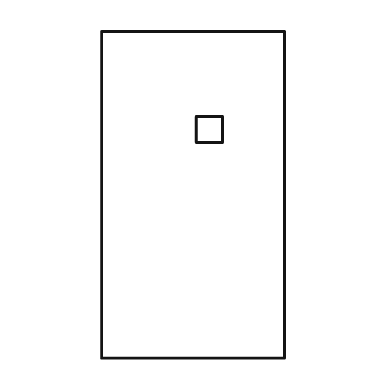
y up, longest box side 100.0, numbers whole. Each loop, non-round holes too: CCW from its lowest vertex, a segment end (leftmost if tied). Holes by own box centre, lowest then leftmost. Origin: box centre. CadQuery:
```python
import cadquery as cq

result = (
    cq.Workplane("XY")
    .moveTo(-28.0, -50.0)
    .lineTo(28.0, -50.0)
    .lineTo(28.0, 50.0)
    .lineTo(-28.0, 50.0)
    .close()
    .moveTo(1.0, 16.0)
    .lineTo(9.0, 16.0)
    .lineTo(9.0, 24.0)
    .lineTo(1.0, 24.0)
    .close()
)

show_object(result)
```